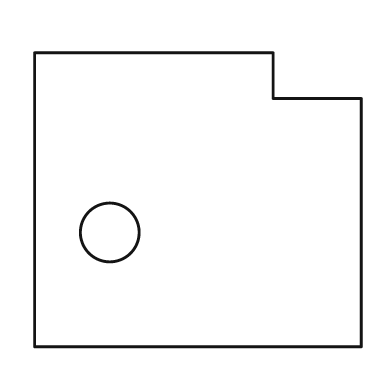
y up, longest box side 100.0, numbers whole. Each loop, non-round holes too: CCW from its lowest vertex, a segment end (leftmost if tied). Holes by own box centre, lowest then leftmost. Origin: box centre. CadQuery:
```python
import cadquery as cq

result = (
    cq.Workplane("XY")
    .moveTo(-50.0, -45.0)
    .lineTo(50.0, -45.0)
    .lineTo(50.0, 31.0)
    .lineTo(23.0, 31.0)
    .lineTo(23.0, 45.0)
    .lineTo(-50.0, 45.0)
    .close()
    .moveTo(-27.0, -10.0)
    .circle(9.0)
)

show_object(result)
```